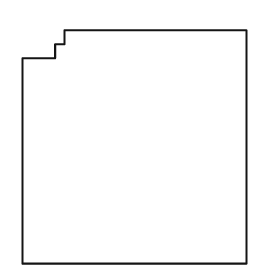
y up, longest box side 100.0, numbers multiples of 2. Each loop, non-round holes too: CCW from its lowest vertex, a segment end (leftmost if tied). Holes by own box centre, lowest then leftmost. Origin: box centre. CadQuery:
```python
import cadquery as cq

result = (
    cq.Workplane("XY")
    .moveTo(-48.0, -50.0)
    .lineTo(48.0, -50.0)
    .lineTo(48.0, 50.0)
    .lineTo(-30.0, 50.0)
    .lineTo(-30.0, 44.0)
    .lineTo(-34.0, 44.0)
    .lineTo(-34.0, 38.0)
    .lineTo(-48.0, 38.0)
    .close()
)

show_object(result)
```